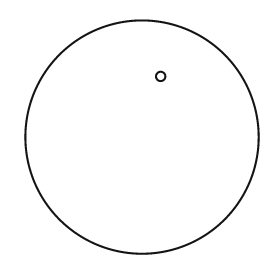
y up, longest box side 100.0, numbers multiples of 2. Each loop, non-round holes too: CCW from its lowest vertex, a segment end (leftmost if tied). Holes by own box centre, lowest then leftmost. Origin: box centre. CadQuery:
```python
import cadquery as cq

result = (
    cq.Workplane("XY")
    .moveTo(0.0, 0.0)
    .circle(50.0)
    .moveTo(8.0, 26.0)
    .circle(2.0)
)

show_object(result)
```